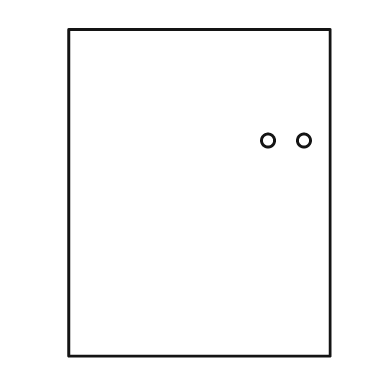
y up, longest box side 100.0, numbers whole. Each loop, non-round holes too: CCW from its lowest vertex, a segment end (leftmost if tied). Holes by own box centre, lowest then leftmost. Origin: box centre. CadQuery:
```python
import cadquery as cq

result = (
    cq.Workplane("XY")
    .moveTo(-40.0, -50.0)
    .lineTo(40.0, -50.0)
    .lineTo(40.0, 50.0)
    .lineTo(-40.0, 50.0)
    .close()
    .moveTo(21.0, 16.0)
    .circle(2.0)
    .moveTo(32.0, 16.0)
    .circle(2.0)
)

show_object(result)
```